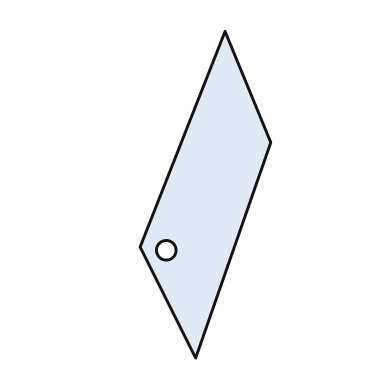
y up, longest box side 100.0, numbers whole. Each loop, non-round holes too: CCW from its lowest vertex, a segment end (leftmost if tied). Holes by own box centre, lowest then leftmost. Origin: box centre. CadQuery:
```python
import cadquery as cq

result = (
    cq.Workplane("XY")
    .moveTo(-3.0, -50.0)
    .lineTo(20.0, 16.0)
    .lineTo(6.0, 50.0)
    .lineTo(-20.0, -16.0)
    .close()
    .moveTo(-12.0, -17.0)
    .circle(3.0)
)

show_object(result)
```